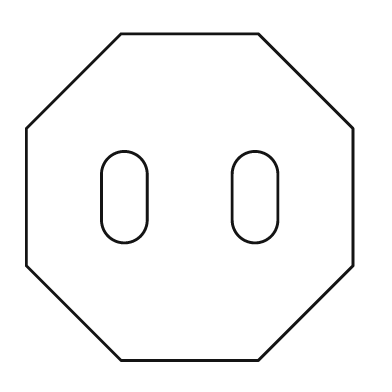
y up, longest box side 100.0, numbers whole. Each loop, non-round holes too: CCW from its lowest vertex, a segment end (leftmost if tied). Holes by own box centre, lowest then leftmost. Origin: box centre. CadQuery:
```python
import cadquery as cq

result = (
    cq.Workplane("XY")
    .moveTo(-21.0, -50.0)
    .lineTo(21.0, -50.0)
    .lineTo(50.0, -21.0)
    .lineTo(50.0, 21.0)
    .lineTo(21.0, 50.0)
    .lineTo(-21.0, 50.0)
    .lineTo(-50.0, 21.0)
    .lineTo(-50.0, -21.0)
    .close()
    .moveTo(-27.0, -7.0)
    .threePointArc((-20.0, -14.0), (-13.0, -7.0))
    .lineTo(-13.0, 7.0)
    .threePointArc((-20.0, 14.0), (-27.0, 7.0))
    .close()
    .moveTo(13.0, -7.0)
    .threePointArc((20.0, -14.0), (27.0, -7.0))
    .lineTo(27.0, 7.0)
    .threePointArc((20.0, 14.0), (13.0, 7.0))
    .close()
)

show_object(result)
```